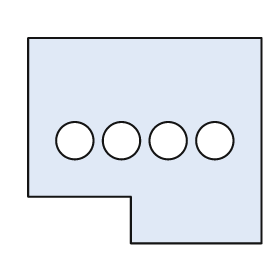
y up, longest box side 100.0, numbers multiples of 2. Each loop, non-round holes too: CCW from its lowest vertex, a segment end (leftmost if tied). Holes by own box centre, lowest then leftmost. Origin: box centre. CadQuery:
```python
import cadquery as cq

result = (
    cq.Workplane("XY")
    .moveTo(-6.0, -44.0)
    .lineTo(50.0, -44.0)
    .lineTo(50.0, 44.0)
    .lineTo(-50.0, 44.0)
    .lineTo(-50.0, -24.0)
    .lineTo(-6.0, -24.0)
    .close()
    .moveTo(-30.0, 0.0)
    .circle(8.0)
    .moveTo(-10.0, 0.0)
    .circle(8.0)
    .moveTo(10.0, 0.0)
    .circle(8.0)
    .moveTo(30.0, 0.0)
    .circle(8.0)
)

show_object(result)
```